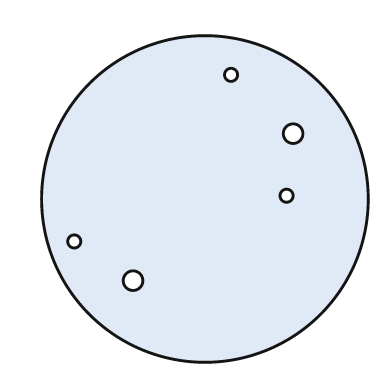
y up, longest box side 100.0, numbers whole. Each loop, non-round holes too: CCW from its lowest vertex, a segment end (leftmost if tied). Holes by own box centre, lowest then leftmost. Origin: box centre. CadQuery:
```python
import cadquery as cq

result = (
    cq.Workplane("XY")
    .moveTo(0.0, 0.0)
    .circle(50.0)
    .moveTo(-22.0, -25.0)
    .circle(3.0)
    .moveTo(-40.0, -13.0)
    .circle(2.0)
    .moveTo(25.0, 1.0)
    .circle(2.0)
    .moveTo(27.0, 20.0)
    .circle(3.0)
    .moveTo(8.0, 38.0)
    .circle(2.0)
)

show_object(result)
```